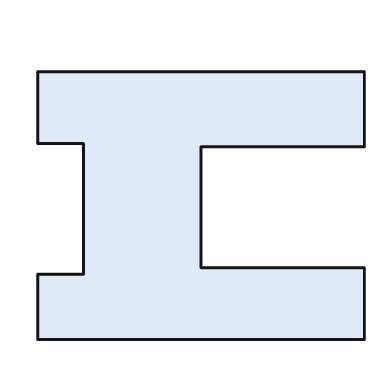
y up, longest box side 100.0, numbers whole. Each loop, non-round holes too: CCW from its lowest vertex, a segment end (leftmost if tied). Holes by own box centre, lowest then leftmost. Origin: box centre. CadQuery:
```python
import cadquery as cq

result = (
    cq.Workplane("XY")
    .moveTo(-50.0, -41.0)
    .lineTo(50.0, -41.0)
    .lineTo(50.0, -19.0)
    .lineTo(0.0, -19.0)
    .lineTo(0.0, 18.0)
    .lineTo(50.0, 18.0)
    .lineTo(50.0, 41.0)
    .lineTo(-50.0, 41.0)
    .lineTo(-50.0, 19.0)
    .lineTo(-36.0, 19.0)
    .lineTo(-36.0, -21.0)
    .lineTo(-50.0, -21.0)
    .close()
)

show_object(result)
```